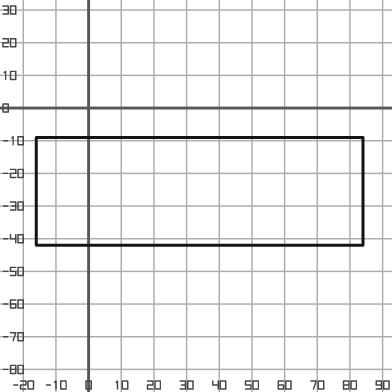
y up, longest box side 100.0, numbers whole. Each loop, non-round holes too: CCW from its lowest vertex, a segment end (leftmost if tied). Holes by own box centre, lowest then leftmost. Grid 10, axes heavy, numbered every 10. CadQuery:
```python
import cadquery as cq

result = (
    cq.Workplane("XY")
    .moveTo(-16.0, -42.0)
    .lineTo(84.0, -42.0)
    .lineTo(84.0, -9.0)
    .lineTo(-16.0, -9.0)
    .close()
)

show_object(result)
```